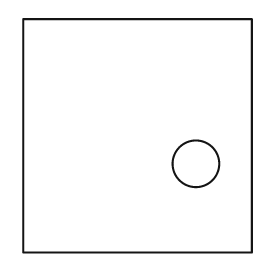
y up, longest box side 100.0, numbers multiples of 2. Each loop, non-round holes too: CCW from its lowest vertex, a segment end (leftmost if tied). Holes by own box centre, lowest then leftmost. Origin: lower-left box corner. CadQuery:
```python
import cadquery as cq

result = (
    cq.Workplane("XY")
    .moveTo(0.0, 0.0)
    .lineTo(98.0, 0.0)
    .lineTo(98.0, 100.0)
    .lineTo(0.0, 100.0)
    .close()
    .moveTo(74.0, 38.0)
    .circle(10.0)
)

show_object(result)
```